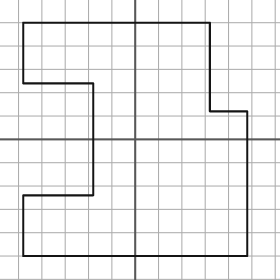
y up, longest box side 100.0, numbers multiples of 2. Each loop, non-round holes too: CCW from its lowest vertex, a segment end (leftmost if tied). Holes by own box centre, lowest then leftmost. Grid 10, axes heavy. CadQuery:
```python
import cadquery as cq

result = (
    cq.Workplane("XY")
    .moveTo(-48.0, -50.0)
    .lineTo(48.0, -50.0)
    .lineTo(48.0, 12.0)
    .lineTo(32.0, 12.0)
    .lineTo(32.0, 50.0)
    .lineTo(-48.0, 50.0)
    .lineTo(-48.0, 24.0)
    .lineTo(-18.0, 24.0)
    .lineTo(-18.0, -24.0)
    .lineTo(-48.0, -24.0)
    .close()
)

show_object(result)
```